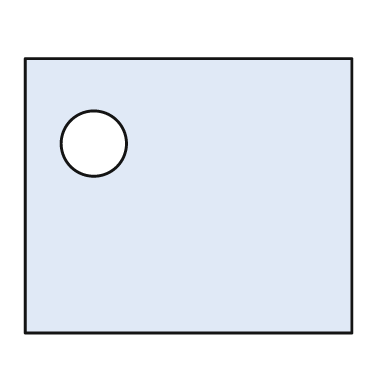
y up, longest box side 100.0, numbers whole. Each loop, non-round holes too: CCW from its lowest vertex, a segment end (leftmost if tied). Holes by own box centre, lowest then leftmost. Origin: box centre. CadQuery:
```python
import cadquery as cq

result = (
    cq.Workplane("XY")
    .moveTo(-50.0, -42.0)
    .lineTo(50.0, -42.0)
    .lineTo(50.0, 42.0)
    .lineTo(-50.0, 42.0)
    .close()
    .moveTo(-29.0, 16.0)
    .circle(10.0)
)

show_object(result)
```